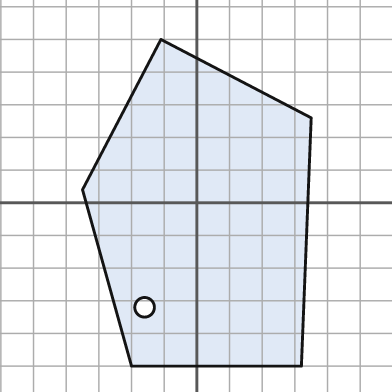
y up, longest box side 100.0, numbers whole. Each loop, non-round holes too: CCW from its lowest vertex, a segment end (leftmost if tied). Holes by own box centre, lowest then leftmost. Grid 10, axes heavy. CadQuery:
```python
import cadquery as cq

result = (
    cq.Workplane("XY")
    .moveTo(-20.0, -50.0)
    .lineTo(32.0, -50.0)
    .lineTo(35.0, 26.0)
    .lineTo(-11.0, 50.0)
    .lineTo(-35.0, 4.0)
    .close()
    .moveTo(-16.0, -32.0)
    .circle(3.0)
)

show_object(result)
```